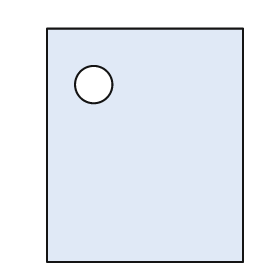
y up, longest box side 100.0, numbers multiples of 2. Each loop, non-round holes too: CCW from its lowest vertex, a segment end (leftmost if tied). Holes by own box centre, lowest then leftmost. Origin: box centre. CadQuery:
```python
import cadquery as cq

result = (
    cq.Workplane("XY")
    .moveTo(-42.0, -50.0)
    .lineTo(42.0, -50.0)
    .lineTo(42.0, 50.0)
    .lineTo(-42.0, 50.0)
    .close()
    .moveTo(-22.0, 26.0)
    .circle(8.0)
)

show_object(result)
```